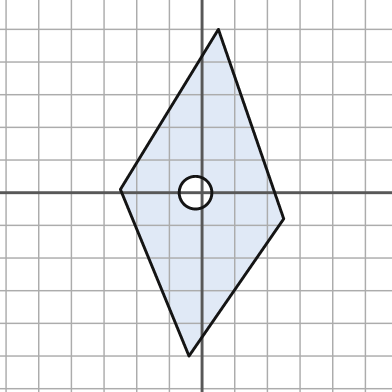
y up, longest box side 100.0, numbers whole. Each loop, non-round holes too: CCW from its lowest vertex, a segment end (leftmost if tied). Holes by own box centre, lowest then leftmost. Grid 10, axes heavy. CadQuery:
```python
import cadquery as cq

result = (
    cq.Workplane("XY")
    .moveTo(-4.0, -50.0)
    .lineTo(25.0, -8.0)
    .lineTo(5.0, 50.0)
    .lineTo(-25.0, 1.0)
    .close()
    .moveTo(-2.0, 0.0)
    .circle(5.0)
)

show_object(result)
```